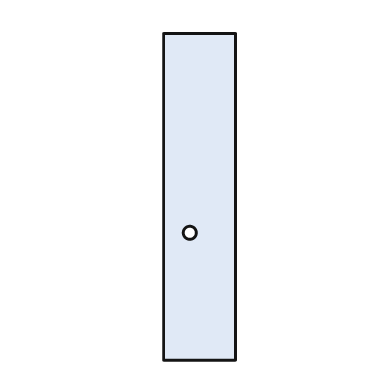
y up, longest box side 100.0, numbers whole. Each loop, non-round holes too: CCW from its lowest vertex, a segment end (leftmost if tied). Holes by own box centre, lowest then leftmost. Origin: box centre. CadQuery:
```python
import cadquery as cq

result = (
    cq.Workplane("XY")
    .moveTo(-11.0, -50.0)
    .lineTo(11.0, -50.0)
    .lineTo(11.0, 50.0)
    .lineTo(-11.0, 50.0)
    .close()
    .moveTo(-3.0, -11.0)
    .circle(2.0)
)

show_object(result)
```